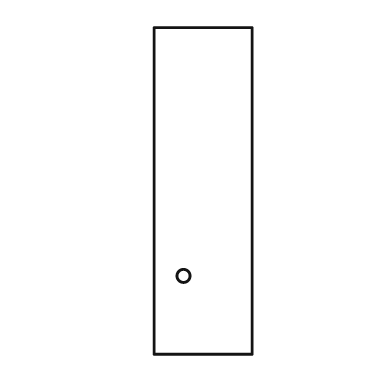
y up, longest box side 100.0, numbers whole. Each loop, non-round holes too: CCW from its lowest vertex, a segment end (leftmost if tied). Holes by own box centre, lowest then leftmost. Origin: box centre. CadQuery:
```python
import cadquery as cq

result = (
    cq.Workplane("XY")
    .moveTo(-15.0, -50.0)
    .lineTo(15.0, -50.0)
    .lineTo(15.0, 50.0)
    .lineTo(-15.0, 50.0)
    .close()
    .moveTo(-6.0, -26.0)
    .circle(2.0)
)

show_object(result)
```